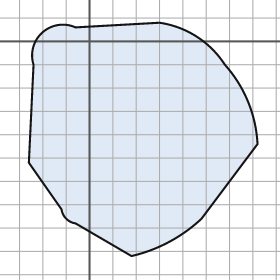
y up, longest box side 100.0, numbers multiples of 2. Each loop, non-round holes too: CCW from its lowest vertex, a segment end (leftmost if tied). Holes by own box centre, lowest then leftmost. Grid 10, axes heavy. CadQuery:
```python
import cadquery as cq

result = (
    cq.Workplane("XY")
    .moveTo(18.0, -92.0)
    .threePointArc((34.0, -86.0), (48.0, -76.0))
    .lineTo(72.0, -44.0)
    .threePointArc((68.0, -26.0), (58.0, -10.0))
    .threePointArc((46.0, 2.0), (30.0, 8.0))
    .lineTo(-6.0, 6.0)
    .threePointArc((-20.0, 4.0), (-24.0, -10.0))
    .lineTo(-26.0, -52.0)
    .lineTo(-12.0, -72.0)
    .threePointArc((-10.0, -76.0), (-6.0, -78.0))
    .close()
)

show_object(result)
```